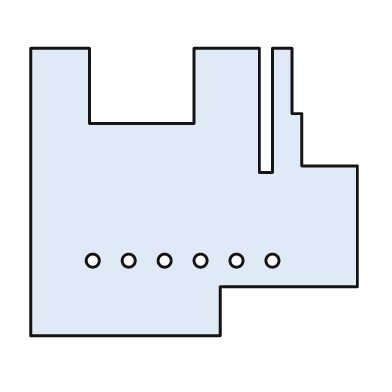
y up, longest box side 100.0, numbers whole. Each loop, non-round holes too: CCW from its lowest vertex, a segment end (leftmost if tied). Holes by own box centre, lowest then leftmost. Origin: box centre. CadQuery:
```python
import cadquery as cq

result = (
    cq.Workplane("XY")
    .moveTo(-50.0, -44.0)
    .lineTo(8.0, -44.0)
    .lineTo(8.0, -29.0)
    .lineTo(50.0, -29.0)
    .lineTo(50.0, 8.0)
    .lineTo(33.0, 8.0)
    .lineTo(33.0, 24.0)
    .lineTo(30.0, 24.0)
    .lineTo(30.0, 44.0)
    .lineTo(24.0, 44.0)
    .lineTo(24.0, 6.0)
    .lineTo(20.0, 6.0)
    .lineTo(20.0, 44.0)
    .lineTo(0.0, 44.0)
    .lineTo(0.0, 21.0)
    .lineTo(-32.0, 21.0)
    .lineTo(-32.0, 44.0)
    .lineTo(-50.0, 44.0)
    .close()
    .moveTo(-31.0, -21.0)
    .circle(2.0)
    .moveTo(-20.0, -21.0)
    .circle(2.0)
    .moveTo(-9.0, -21.0)
    .circle(2.0)
    .moveTo(2.0, -21.0)
    .circle(2.0)
    .moveTo(13.0, -21.0)
    .circle(2.0)
    .moveTo(24.0, -21.0)
    .circle(2.0)
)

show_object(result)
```